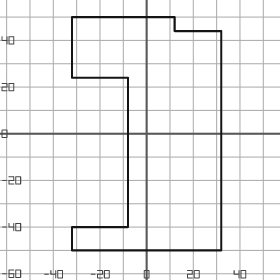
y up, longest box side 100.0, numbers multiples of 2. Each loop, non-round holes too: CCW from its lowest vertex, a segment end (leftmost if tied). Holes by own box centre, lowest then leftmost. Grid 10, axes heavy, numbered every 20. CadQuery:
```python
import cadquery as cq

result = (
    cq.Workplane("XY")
    .moveTo(-32.0, -50.0)
    .lineTo(32.0, -50.0)
    .lineTo(32.0, 44.0)
    .lineTo(12.0, 44.0)
    .lineTo(12.0, 50.0)
    .lineTo(-32.0, 50.0)
    .lineTo(-32.0, 24.0)
    .lineTo(-8.0, 24.0)
    .lineTo(-8.0, -40.0)
    .lineTo(-32.0, -40.0)
    .close()
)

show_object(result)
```